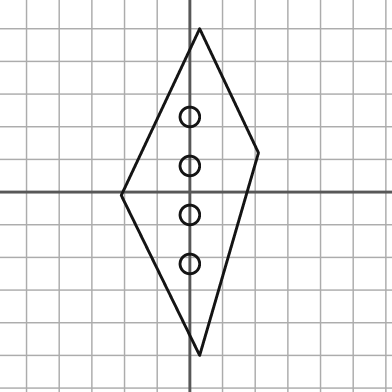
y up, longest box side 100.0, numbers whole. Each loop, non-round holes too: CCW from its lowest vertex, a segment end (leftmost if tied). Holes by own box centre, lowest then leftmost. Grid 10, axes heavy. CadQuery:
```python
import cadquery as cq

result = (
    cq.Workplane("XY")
    .moveTo(3.0, -50.0)
    .lineTo(21.0, 12.0)
    .lineTo(3.0, 50.0)
    .lineTo(-21.0, -1.0)
    .close()
    .moveTo(0.0, -22.0)
    .circle(3.0)
    .moveTo(0.0, -7.0)
    .circle(3.0)
    .moveTo(0.0, 8.0)
    .circle(3.0)
    .moveTo(0.0, 23.0)
    .circle(3.0)
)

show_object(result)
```